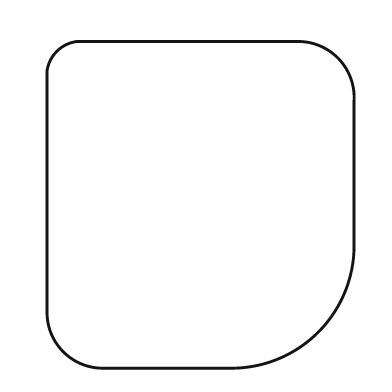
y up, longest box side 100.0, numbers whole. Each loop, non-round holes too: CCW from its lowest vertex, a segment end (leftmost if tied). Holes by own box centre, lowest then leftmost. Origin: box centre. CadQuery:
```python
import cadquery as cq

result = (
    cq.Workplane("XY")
    .moveTo(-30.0, -50.0)
    .lineTo(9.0, -50.0)
    .threePointArc((36.0, -39.0), (47.0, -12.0))
    .lineTo(47.0, 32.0)
    .threePointArc((42.0, 45.0), (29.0, 50.0))
    .lineTo(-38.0, 50.0)
    .threePointArc((-44.0, 47.0), (-47.0, 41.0))
    .lineTo(-47.0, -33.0)
    .threePointArc((-42.0, -45.0), (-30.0, -50.0))
    .close()
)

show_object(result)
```